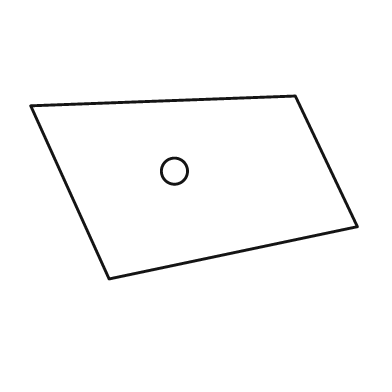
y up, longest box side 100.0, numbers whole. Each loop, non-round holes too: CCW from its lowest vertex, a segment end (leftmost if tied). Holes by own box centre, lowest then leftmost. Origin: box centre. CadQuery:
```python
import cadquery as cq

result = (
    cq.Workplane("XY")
    .moveTo(-26.0, -28.0)
    .lineTo(50.0, -12.0)
    .lineTo(31.0, 28.0)
    .lineTo(-50.0, 25.0)
    .close()
    .moveTo(-6.0, 5.0)
    .circle(4.0)
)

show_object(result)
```